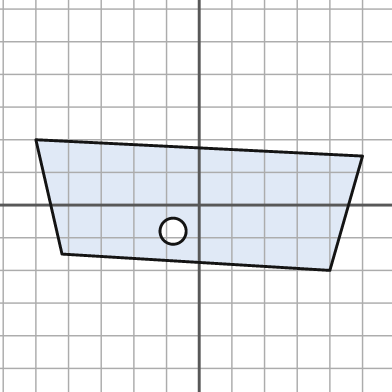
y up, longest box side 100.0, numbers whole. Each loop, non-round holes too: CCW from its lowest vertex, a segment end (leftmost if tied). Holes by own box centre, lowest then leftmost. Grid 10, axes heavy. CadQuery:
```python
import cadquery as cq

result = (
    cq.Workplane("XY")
    .moveTo(40.0, -20.0)
    .lineTo(50.0, 15.0)
    .lineTo(-50.0, 20.0)
    .lineTo(-42.0, -15.0)
    .close()
    .moveTo(-8.0, -8.0)
    .circle(4.0)
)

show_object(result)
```